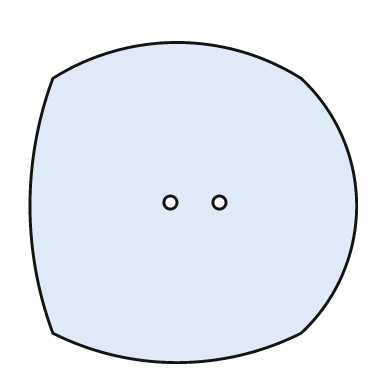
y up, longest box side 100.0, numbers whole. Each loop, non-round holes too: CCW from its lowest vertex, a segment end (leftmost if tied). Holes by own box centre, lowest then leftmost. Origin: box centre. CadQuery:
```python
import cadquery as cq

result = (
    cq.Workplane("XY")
    .moveTo(-43.0, -40.0)
    .threePointArc((-5.0, -49.0), (33.0, -40.0))
    .threePointArc((50.0, -1.0), (33.0, 38.0))
    .threePointArc((-5.0, 49.0), (-43.0, 38.0))
    .threePointArc((-50.0, -1.0), (-43.0, -40.0))
    .close()
    .moveTo(-7.0, 0.0)
    .circle(2.0)
    .moveTo(8.0, 0.0)
    .circle(2.0)
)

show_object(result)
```